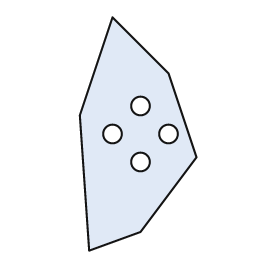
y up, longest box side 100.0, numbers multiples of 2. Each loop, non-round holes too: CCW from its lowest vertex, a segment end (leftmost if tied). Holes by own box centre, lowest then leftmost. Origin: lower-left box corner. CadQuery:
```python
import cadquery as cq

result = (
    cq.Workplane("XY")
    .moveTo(4.0, 0.0)
    .lineTo(26.0, 8.0)
    .lineTo(50.0, 40.0)
    .lineTo(38.0, 76.0)
    .lineTo(14.0, 100.0)
    .lineTo(0.0, 58.0)
    .close()
    .moveTo(26.0, 38.0)
    .circle(4.0)
    .moveTo(14.0, 50.0)
    .circle(4.0)
    .moveTo(38.0, 50.0)
    .circle(4.0)
    .moveTo(26.0, 62.0)
    .circle(4.0)
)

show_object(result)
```